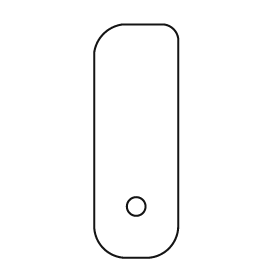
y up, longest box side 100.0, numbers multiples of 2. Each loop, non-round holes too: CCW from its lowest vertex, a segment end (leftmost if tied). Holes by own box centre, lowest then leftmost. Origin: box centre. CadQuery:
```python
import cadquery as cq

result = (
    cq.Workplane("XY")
    .moveTo(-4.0, -50.0)
    .lineTo(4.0, -50.0)
    .threePointArc((14.0, -46.0), (18.0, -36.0))
    .lineTo(18.0, 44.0)
    .threePointArc((16.0, 48.0), (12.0, 50.0))
    .lineTo(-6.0, 50.0)
    .threePointArc((-14.0, 46.0), (-18.0, 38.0))
    .lineTo(-18.0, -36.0)
    .threePointArc((-14.0, -46.0), (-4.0, -50.0))
    .close()
    .moveTo(0.0, -28.0)
    .circle(4.0)
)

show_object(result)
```